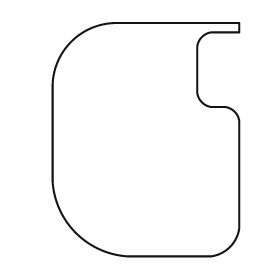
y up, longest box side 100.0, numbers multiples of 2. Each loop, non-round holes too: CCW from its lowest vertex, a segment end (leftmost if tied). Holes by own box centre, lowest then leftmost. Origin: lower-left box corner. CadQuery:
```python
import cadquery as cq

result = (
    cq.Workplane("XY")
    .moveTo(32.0, 0.0)
    .lineTo(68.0, 0.0)
    .threePointArc((76.0, 4.0), (80.0, 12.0))
    .lineTo(80.0, 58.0)
    .threePointArc((78.0, 62.0), (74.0, 64.0))
    .lineTo(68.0, 64.0)
    .threePointArc((64.0, 66.0), (62.0, 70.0))
    .lineTo(62.0, 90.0)
    .threePointArc((64.0, 94.0), (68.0, 96.0))
    .lineTo(80.0, 96.0)
    .lineTo(80.0, 100.0)
    .lineTo(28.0, 100.0)
    .threePointArc((8.0, 92.0), (0.0, 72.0))
    .lineTo(0.0, 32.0)
    .threePointArc((10.0, 10.0), (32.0, 0.0))
    .close()
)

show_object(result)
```